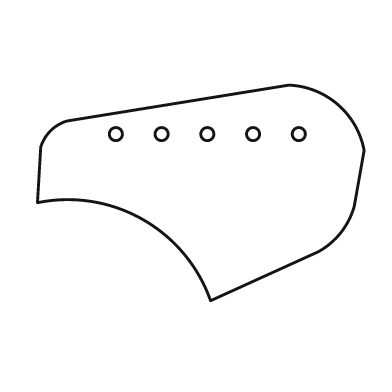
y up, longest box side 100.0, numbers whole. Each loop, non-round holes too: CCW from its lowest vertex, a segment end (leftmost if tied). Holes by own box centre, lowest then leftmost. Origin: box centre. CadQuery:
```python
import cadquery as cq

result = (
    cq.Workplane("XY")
    .moveTo(3.0, -33.0)
    .lineTo(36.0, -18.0)
    .threePointArc((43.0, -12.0), (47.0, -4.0))
    .lineTo(50.0, 13.0)
    .threePointArc((42.0, 27.0), (27.0, 33.0))
    .lineTo(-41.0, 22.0)
    .threePointArc((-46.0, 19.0), (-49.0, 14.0))
    .lineTo(-50.0, -3.0)
    .threePointArc((-18.0, -8.0), (3.0, -33.0))
    .close()
    .moveTo(-26.0, 18.0)
    .circle(2.0)
    .moveTo(-12.0, 18.0)
    .circle(2.0)
    .moveTo(2.0, 18.0)
    .circle(2.0)
    .moveTo(16.0, 18.0)
    .circle(2.0)
    .moveTo(30.0, 18.0)
    .circle(2.0)
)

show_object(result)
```